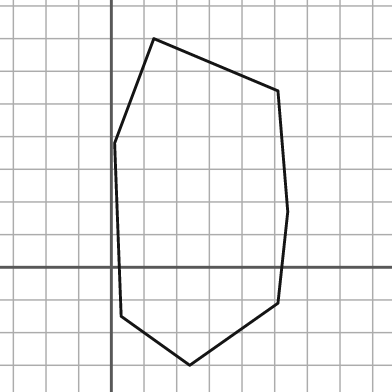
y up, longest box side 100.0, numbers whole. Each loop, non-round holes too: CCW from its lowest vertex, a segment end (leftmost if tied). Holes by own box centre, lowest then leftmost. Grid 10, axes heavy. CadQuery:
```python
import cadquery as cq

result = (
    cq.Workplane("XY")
    .moveTo(24.0, -30.0)
    .lineTo(51.0, -11.0)
    .lineTo(54.0, 17.0)
    .lineTo(51.0, 54.0)
    .lineTo(13.0, 70.0)
    .lineTo(1.0, 38.0)
    .lineTo(3.0, -15.0)
    .close()
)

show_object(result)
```